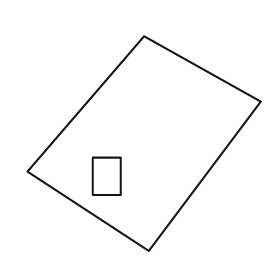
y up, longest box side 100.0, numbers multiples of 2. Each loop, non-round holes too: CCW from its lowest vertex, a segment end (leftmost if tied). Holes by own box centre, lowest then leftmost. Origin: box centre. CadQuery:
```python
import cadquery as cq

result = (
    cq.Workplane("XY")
    .moveTo(2.0, -46.0)
    .lineTo(50.0, 18.0)
    .lineTo(0.0, 46.0)
    .lineTo(-50.0, -12.0)
    .close()
    .moveTo(-22.0, -22.0)
    .lineTo(-10.0, -22.0)
    .lineTo(-10.0, -6.0)
    .lineTo(-22.0, -6.0)
    .close()
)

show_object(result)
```